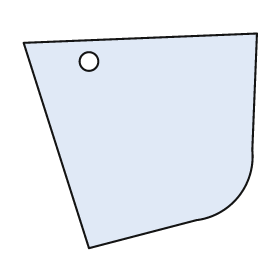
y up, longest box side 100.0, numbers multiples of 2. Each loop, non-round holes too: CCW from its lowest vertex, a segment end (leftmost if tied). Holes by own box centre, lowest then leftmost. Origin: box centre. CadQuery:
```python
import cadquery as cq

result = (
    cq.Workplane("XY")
    .moveTo(-22.0, -46.0)
    .lineTo(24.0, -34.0)
    .threePointArc((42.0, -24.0), (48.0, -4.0))
    .lineTo(50.0, 46.0)
    .lineTo(-50.0, 42.0)
    .close()
    .moveTo(-22.0, 34.0)
    .circle(4.0)
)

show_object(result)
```